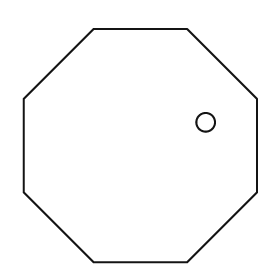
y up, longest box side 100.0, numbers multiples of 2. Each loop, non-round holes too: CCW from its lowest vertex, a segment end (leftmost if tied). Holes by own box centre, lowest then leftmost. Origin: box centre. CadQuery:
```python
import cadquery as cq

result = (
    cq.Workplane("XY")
    .moveTo(-20.0, -50.0)
    .lineTo(20.0, -50.0)
    .lineTo(50.0, -20.0)
    .lineTo(50.0, 20.0)
    .lineTo(20.0, 50.0)
    .lineTo(-20.0, 50.0)
    .lineTo(-50.0, 20.0)
    .lineTo(-50.0, -20.0)
    .close()
    .moveTo(28.0, 10.0)
    .circle(4.0)
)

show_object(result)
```